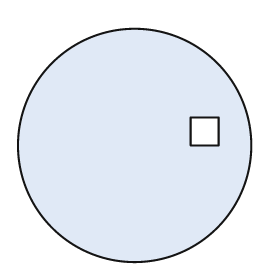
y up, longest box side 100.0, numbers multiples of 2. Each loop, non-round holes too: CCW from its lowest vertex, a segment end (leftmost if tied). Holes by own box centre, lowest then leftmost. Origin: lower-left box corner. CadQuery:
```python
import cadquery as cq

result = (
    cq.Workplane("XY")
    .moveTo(50.0, 50.0)
    .circle(50.0)
    .moveTo(74.0, 50.0)
    .lineTo(86.0, 50.0)
    .lineTo(86.0, 62.0)
    .lineTo(74.0, 62.0)
    .close()
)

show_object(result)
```